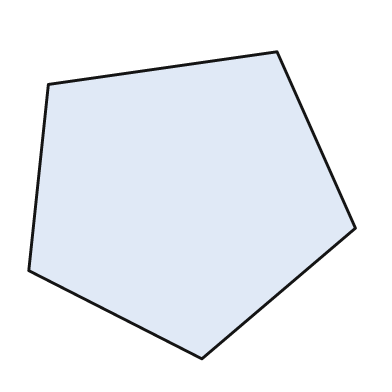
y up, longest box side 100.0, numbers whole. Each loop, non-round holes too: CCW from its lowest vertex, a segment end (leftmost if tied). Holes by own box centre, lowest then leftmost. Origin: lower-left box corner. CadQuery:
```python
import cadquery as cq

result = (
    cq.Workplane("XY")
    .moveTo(53.0, 0.0)
    .lineTo(100.0, 40.0)
    .lineTo(76.0, 94.0)
    .lineTo(6.0, 84.0)
    .lineTo(0.0, 27.0)
    .close()
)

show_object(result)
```